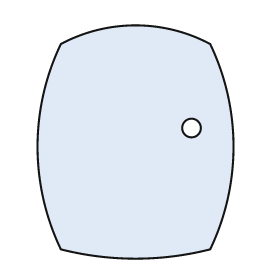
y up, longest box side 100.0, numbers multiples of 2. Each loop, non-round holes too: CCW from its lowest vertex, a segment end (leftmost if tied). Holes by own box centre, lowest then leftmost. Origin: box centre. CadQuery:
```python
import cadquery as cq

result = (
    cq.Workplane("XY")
    .moveTo(-32.0, -46.0)
    .threePointArc((0.0, -50.0), (32.0, -46.0))
    .threePointArc((42.0, -2.0), (32.0, 42.0))
    .threePointArc((0.0, 50.0), (-32.0, 42.0))
    .threePointArc((-42.0, -2.0), (-32.0, -46.0))
    .close()
    .moveTo(24.0, 6.0)
    .circle(4.0)
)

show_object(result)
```